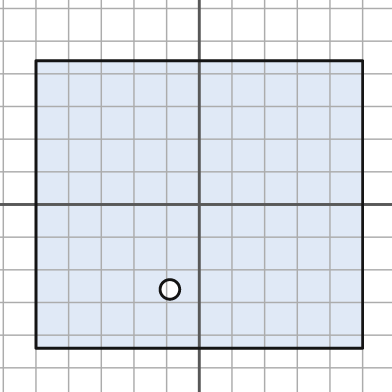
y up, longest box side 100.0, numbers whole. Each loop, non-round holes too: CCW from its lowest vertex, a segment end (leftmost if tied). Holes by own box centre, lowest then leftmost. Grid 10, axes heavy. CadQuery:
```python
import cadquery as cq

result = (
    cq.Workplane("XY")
    .moveTo(-50.0, -44.0)
    .lineTo(50.0, -44.0)
    .lineTo(50.0, 44.0)
    .lineTo(-50.0, 44.0)
    .close()
    .moveTo(-9.0, -26.0)
    .circle(3.0)
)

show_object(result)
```